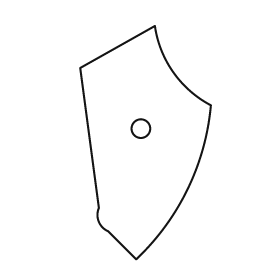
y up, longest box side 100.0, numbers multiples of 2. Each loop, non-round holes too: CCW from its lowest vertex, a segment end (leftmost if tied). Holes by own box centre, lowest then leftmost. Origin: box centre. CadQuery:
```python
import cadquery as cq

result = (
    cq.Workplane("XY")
    .moveTo(-4.0, -50.0)
    .threePointArc((18.0, -20.0), (28.0, 16.0))
    .threePointArc((12.0, 30.0), (4.0, 50.0))
    .lineTo(-28.0, 32.0)
    .lineTo(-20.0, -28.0)
    .threePointArc((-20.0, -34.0), (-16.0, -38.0))
    .close()
    .moveTo(-2.0, 6.0)
    .circle(4.0)
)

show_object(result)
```